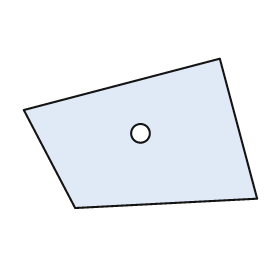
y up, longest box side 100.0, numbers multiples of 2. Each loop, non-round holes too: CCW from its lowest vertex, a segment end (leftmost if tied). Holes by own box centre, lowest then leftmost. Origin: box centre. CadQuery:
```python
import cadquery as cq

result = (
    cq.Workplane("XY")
    .moveTo(-28.0, -32.0)
    .lineTo(50.0, -28.0)
    .lineTo(34.0, 32.0)
    .lineTo(-50.0, 10.0)
    .close()
    .moveTo(0.0, 0.0)
    .circle(4.0)
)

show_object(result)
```